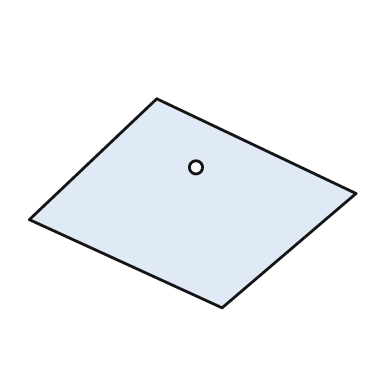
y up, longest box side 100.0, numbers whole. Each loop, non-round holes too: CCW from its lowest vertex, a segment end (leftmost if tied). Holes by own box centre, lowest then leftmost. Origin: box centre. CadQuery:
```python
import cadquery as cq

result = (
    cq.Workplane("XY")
    .moveTo(9.0, -32.0)
    .lineTo(50.0, 3.0)
    .lineTo(-11.0, 32.0)
    .lineTo(-50.0, -5.0)
    .close()
    .moveTo(1.0, 11.0)
    .circle(2.0)
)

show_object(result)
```